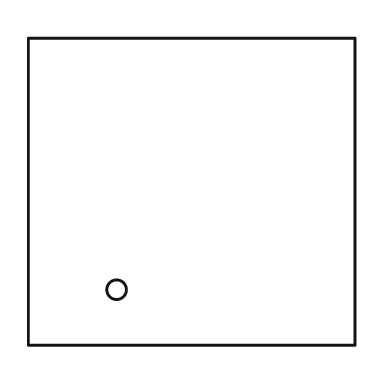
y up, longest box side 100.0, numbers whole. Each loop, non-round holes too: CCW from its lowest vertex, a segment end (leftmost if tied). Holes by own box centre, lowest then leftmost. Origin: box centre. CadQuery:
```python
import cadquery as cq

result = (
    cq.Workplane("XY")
    .moveTo(-50.0, -47.0)
    .lineTo(50.0, -47.0)
    .lineTo(50.0, 47.0)
    .lineTo(-50.0, 47.0)
    .close()
    .moveTo(-23.0, -30.0)
    .circle(3.0)
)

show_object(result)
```